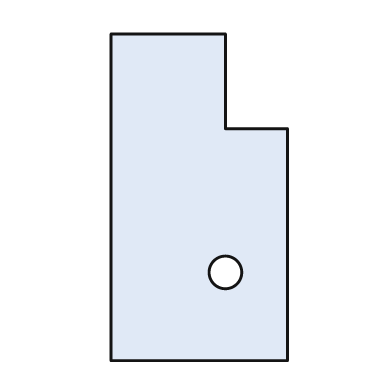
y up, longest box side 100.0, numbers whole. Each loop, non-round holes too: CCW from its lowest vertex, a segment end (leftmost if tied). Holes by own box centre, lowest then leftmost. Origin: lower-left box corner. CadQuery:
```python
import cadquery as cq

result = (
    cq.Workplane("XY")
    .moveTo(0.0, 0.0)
    .lineTo(54.0, 0.0)
    .lineTo(54.0, 71.0)
    .lineTo(35.0, 71.0)
    .lineTo(35.0, 100.0)
    .lineTo(0.0, 100.0)
    .close()
    .moveTo(35.0, 27.0)
    .circle(5.0)
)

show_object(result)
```